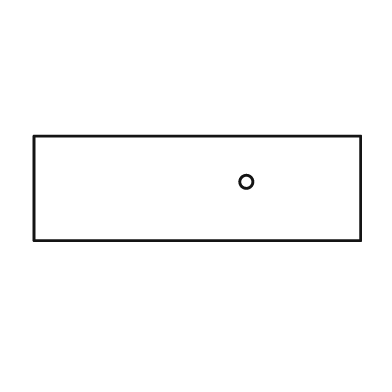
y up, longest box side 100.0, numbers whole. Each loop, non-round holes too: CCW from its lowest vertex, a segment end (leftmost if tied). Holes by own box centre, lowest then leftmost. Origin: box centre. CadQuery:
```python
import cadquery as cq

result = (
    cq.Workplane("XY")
    .moveTo(-50.0, -16.0)
    .lineTo(50.0, -16.0)
    .lineTo(50.0, 16.0)
    .lineTo(-50.0, 16.0)
    .close()
    .moveTo(15.0, 2.0)
    .circle(2.0)
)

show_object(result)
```